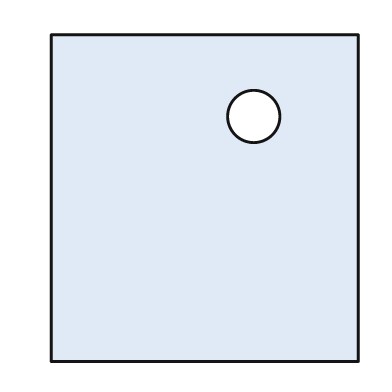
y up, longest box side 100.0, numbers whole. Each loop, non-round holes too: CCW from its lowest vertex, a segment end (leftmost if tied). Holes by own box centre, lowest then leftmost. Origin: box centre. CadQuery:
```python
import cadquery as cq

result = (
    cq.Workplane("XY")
    .moveTo(-47.0, -50.0)
    .lineTo(47.0, -50.0)
    .lineTo(47.0, 50.0)
    .lineTo(-47.0, 50.0)
    .close()
    .moveTo(15.0, 25.0)
    .circle(8.0)
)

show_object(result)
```